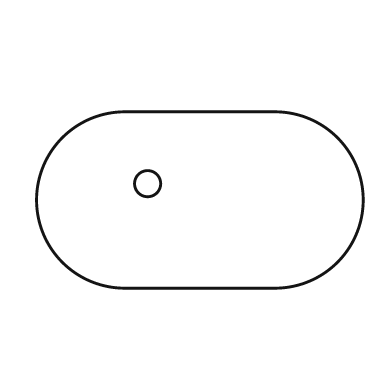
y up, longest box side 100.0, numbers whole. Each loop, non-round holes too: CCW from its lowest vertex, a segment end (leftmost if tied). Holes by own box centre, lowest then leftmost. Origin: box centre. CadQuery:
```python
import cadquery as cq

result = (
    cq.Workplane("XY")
    .moveTo(-23.0, -27.0)
    .lineTo(23.0, -27.0)
    .threePointArc((50.0, 0.0), (23.0, 27.0))
    .lineTo(-23.0, 27.0)
    .threePointArc((-50.0, 0.0), (-23.0, -27.0))
    .close()
    .moveTo(-16.0, 5.0)
    .circle(4.0)
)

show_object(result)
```